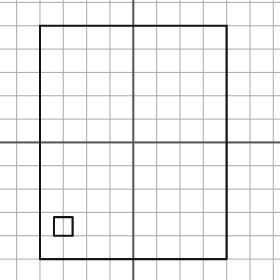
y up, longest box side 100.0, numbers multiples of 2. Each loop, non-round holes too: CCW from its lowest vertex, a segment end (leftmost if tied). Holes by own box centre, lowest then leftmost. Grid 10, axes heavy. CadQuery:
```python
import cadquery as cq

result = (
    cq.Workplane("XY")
    .moveTo(-40.0, -50.0)
    .lineTo(40.0, -50.0)
    .lineTo(40.0, 50.0)
    .lineTo(-40.0, 50.0)
    .close()
    .moveTo(-34.0, -40.0)
    .lineTo(-26.0, -40.0)
    .lineTo(-26.0, -32.0)
    .lineTo(-34.0, -32.0)
    .close()
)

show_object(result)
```